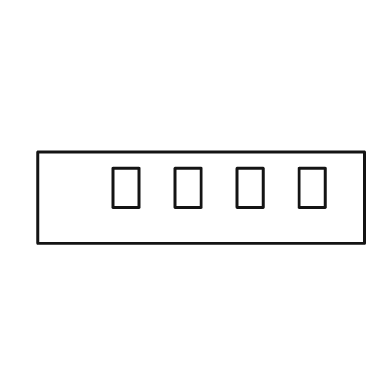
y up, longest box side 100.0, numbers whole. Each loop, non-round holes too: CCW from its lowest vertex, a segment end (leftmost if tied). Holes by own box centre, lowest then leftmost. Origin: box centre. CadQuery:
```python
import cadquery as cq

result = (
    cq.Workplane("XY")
    .moveTo(-50.0, -14.0)
    .lineTo(50.0, -14.0)
    .lineTo(50.0, 14.0)
    .lineTo(-50.0, 14.0)
    .close()
    .moveTo(-27.0, -3.0)
    .lineTo(-19.0, -3.0)
    .lineTo(-19.0, 9.0)
    .lineTo(-27.0, 9.0)
    .close()
    .moveTo(-8.0, -3.0)
    .lineTo(0.0, -3.0)
    .lineTo(0.0, 9.0)
    .lineTo(-8.0, 9.0)
    .close()
    .moveTo(11.0, -3.0)
    .lineTo(19.0, -3.0)
    .lineTo(19.0, 9.0)
    .lineTo(11.0, 9.0)
    .close()
    .moveTo(30.0, -3.0)
    .lineTo(38.0, -3.0)
    .lineTo(38.0, 9.0)
    .lineTo(30.0, 9.0)
    .close()
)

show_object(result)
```